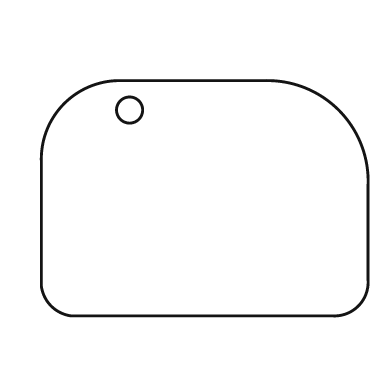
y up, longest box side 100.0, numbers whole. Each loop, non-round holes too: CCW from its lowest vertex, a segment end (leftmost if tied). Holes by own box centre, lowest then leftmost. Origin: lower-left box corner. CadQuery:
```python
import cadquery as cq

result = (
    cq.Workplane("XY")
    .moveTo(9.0, 0.0)
    .lineTo(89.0, 0.0)
    .threePointArc((97.0, 3.0), (100.0, 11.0))
    .lineTo(100.0, 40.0)
    .threePointArc((91.0, 63.0), (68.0, 72.0))
    .lineTo(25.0, 72.0)
    .threePointArc((7.0, 65.0), (0.0, 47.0))
    .lineTo(0.0, 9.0)
    .threePointArc((3.0, 3.0), (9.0, 0.0))
    .close()
    .moveTo(27.0, 63.0)
    .circle(4.0)
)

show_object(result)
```